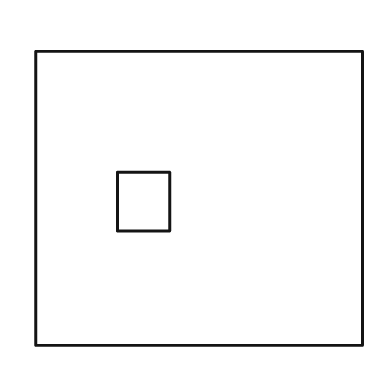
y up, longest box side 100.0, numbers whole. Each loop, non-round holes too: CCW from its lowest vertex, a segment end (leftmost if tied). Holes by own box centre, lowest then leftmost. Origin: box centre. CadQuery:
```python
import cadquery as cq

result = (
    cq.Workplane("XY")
    .moveTo(-50.0, -45.0)
    .lineTo(50.0, -45.0)
    .lineTo(50.0, 45.0)
    .lineTo(-50.0, 45.0)
    .close()
    .moveTo(-25.0, -10.0)
    .lineTo(-9.0, -10.0)
    .lineTo(-9.0, 8.0)
    .lineTo(-25.0, 8.0)
    .close()
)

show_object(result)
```